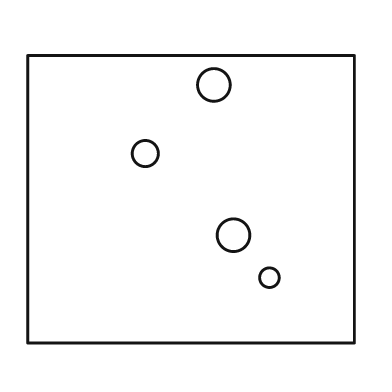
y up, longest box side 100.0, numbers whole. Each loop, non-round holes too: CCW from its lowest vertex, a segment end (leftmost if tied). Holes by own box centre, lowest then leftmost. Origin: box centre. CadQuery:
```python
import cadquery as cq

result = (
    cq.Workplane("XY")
    .moveTo(-50.0, -44.0)
    .lineTo(50.0, -44.0)
    .lineTo(50.0, 44.0)
    .lineTo(-50.0, 44.0)
    .close()
    .moveTo(24.0, -24.0)
    .circle(3.0)
    .moveTo(13.0, -11.0)
    .circle(5.0)
    .moveTo(-14.0, 14.0)
    .circle(4.0)
    .moveTo(7.0, 35.0)
    .circle(5.0)
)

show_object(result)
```